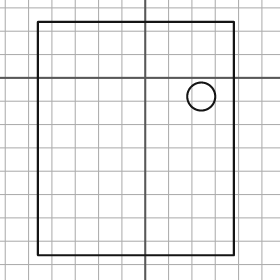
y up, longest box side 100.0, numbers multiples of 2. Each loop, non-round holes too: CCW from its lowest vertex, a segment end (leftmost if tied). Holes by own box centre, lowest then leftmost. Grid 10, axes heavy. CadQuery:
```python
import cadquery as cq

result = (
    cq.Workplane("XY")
    .moveTo(-46.0, -76.0)
    .lineTo(38.0, -76.0)
    .lineTo(38.0, 24.0)
    .lineTo(-46.0, 24.0)
    .close()
    .moveTo(24.0, -8.0)
    .circle(6.0)
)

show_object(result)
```